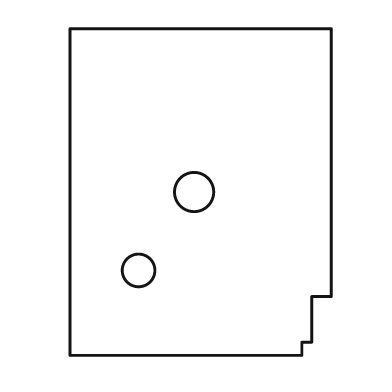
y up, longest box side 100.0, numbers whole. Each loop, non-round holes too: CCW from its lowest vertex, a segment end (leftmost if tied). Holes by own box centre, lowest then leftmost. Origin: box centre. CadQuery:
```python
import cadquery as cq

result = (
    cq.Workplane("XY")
    .moveTo(-40.0, -50.0)
    .lineTo(31.0, -50.0)
    .lineTo(31.0, -46.0)
    .lineTo(34.0, -46.0)
    .lineTo(34.0, -32.0)
    .lineTo(40.0, -32.0)
    .lineTo(40.0, 50.0)
    .lineTo(-40.0, 50.0)
    .close()
    .moveTo(-19.0, -24.0)
    .circle(5.0)
    .moveTo(-2.0, 0.0)
    .circle(6.0)
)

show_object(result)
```